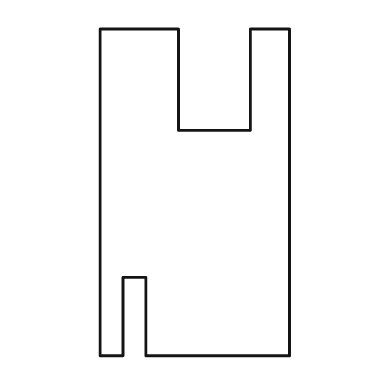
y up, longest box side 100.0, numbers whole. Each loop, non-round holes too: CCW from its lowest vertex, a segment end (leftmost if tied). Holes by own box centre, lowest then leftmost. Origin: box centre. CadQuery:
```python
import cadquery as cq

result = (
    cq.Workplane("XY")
    .moveTo(-29.0, -50.0)
    .lineTo(-22.0, -50.0)
    .lineTo(-22.0, -26.0)
    .lineTo(-15.0, -26.0)
    .lineTo(-15.0, -50.0)
    .lineTo(29.0, -50.0)
    .lineTo(29.0, 50.0)
    .lineTo(17.0, 50.0)
    .lineTo(17.0, 19.0)
    .lineTo(-5.0, 19.0)
    .lineTo(-5.0, 50.0)
    .lineTo(-29.0, 50.0)
    .close()
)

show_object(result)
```